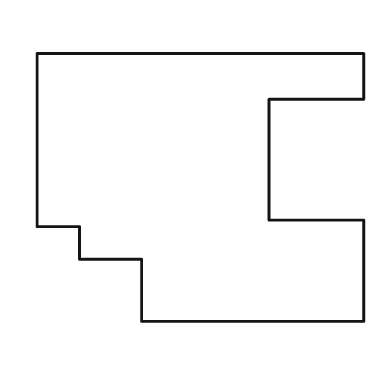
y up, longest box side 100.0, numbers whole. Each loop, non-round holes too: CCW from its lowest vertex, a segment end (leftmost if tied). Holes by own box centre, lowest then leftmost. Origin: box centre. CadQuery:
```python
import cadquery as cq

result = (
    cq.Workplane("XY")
    .moveTo(-18.0, -41.0)
    .lineTo(50.0, -41.0)
    .lineTo(50.0, -10.0)
    .lineTo(21.0, -10.0)
    .lineTo(21.0, 27.0)
    .lineTo(50.0, 27.0)
    .lineTo(50.0, 41.0)
    .lineTo(-50.0, 41.0)
    .lineTo(-50.0, -12.0)
    .lineTo(-37.0, -12.0)
    .lineTo(-37.0, -22.0)
    .lineTo(-18.0, -22.0)
    .close()
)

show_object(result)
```